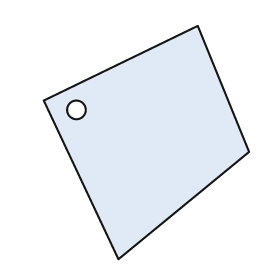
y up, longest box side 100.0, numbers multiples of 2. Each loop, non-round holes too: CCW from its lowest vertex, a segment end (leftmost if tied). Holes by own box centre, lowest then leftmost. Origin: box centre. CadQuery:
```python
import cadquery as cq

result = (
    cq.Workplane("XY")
    .moveTo(-12.0, -50.0)
    .lineTo(44.0, -4.0)
    .lineTo(22.0, 50.0)
    .lineTo(-44.0, 18.0)
    .close()
    .moveTo(-30.0, 14.0)
    .circle(4.0)
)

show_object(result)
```